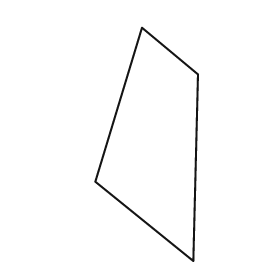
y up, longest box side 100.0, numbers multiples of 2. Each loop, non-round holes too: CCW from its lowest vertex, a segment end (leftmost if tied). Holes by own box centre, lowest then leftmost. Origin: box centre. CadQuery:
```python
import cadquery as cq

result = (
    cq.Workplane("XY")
    .moveTo(20.0, -50.0)
    .lineTo(22.0, 30.0)
    .lineTo(-2.0, 50.0)
    .lineTo(-22.0, -16.0)
    .close()
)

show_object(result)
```